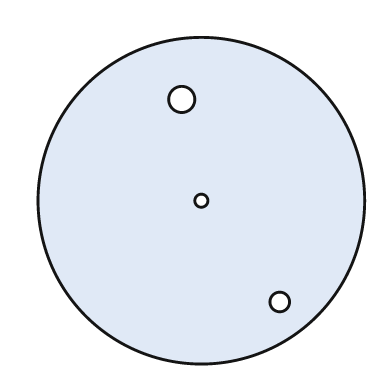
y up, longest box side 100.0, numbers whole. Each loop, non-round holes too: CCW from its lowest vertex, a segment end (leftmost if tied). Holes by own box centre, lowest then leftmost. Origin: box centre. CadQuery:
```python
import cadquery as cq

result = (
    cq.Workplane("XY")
    .moveTo(0.0, 0.0)
    .circle(50.0)
    .moveTo(24.0, -31.0)
    .circle(3.0)
    .moveTo(0.0, 0.0)
    .circle(2.0)
    .moveTo(-6.0, 31.0)
    .circle(4.0)
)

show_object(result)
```